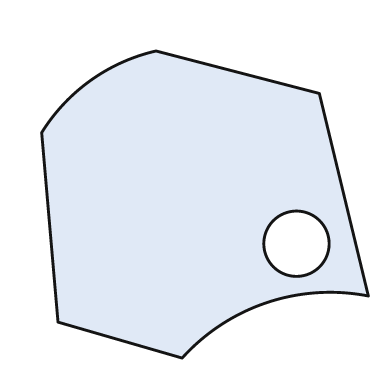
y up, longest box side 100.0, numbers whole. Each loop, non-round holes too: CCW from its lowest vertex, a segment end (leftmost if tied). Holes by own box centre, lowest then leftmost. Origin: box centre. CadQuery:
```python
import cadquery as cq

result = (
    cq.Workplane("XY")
    .moveTo(-7.0, -47.0)
    .threePointArc((19.0, -30.0), (50.0, -28.0))
    .lineTo(35.0, 34.0)
    .lineTo(-15.0, 47.0)
    .threePointArc((-35.0, 38.0), (-50.0, 22.0))
    .lineTo(-45.0, -36.0)
    .close()
    .moveTo(28.0, -12.0)
    .circle(10.0)
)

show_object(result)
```